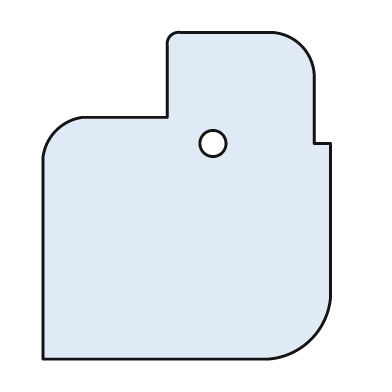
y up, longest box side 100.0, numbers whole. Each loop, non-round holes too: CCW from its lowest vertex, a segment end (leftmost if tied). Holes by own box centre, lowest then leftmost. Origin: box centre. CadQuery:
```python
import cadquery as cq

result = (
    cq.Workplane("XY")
    .moveTo(-44.0, -50.0)
    .lineTo(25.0, -50.0)
    .threePointArc((38.0, -44.0), (44.0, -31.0))
    .lineTo(44.0, 16.0)
    .lineTo(39.0, 16.0)
    .lineTo(39.0, 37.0)
    .threePointArc((35.0, 46.0), (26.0, 50.0))
    .lineTo(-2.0, 50.0)
    .threePointArc((-5.0, 49.0), (-6.0, 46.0))
    .lineTo(-6.0, 24.0)
    .lineTo(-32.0, 24.0)
    .threePointArc((-40.0, 20.0), (-44.0, 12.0))
    .close()
    .moveTo(8.0, 16.0)
    .circle(4.0)
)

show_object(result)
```